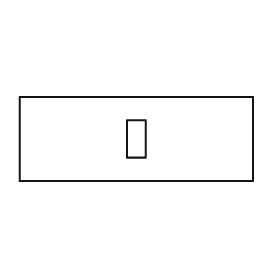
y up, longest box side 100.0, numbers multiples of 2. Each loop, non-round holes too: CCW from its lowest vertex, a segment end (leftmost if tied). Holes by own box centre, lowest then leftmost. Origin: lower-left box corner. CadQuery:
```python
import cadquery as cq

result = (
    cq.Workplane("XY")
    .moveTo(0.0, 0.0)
    .lineTo(100.0, 0.0)
    .lineTo(100.0, 36.0)
    .lineTo(0.0, 36.0)
    .close()
    .moveTo(46.0, 10.0)
    .lineTo(54.0, 10.0)
    .lineTo(54.0, 26.0)
    .lineTo(46.0, 26.0)
    .close()
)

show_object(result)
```